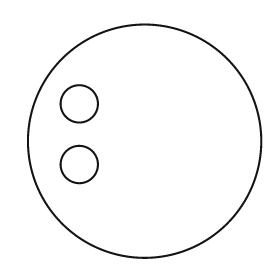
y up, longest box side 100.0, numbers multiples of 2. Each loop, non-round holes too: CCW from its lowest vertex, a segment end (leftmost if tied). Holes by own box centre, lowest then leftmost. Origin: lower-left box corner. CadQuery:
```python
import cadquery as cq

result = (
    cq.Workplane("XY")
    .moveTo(50.0, 50.0)
    .circle(50.0)
    .moveTo(22.0, 40.0)
    .circle(8.0)
    .moveTo(22.0, 66.0)
    .circle(8.0)
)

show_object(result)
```